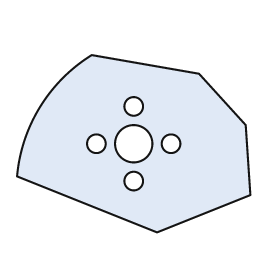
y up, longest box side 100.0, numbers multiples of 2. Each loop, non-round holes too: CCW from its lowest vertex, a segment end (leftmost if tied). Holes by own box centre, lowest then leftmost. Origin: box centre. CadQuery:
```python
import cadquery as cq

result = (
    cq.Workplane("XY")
    .moveTo(10.0, -38.0)
    .lineTo(50.0, -22.0)
    .lineTo(48.0, 8.0)
    .lineTo(28.0, 30.0)
    .lineTo(-18.0, 38.0)
    .threePointArc((-40.0, 16.0), (-50.0, -14.0))
    .close()
    .moveTo(0.0, -16.0)
    .circle(4.0)
    .moveTo(-16.0, 0.0)
    .circle(4.0)
    .moveTo(0.0, 0.0)
    .circle(8.0)
    .moveTo(16.0, 0.0)
    .circle(4.0)
    .moveTo(0.0, 16.0)
    .circle(4.0)
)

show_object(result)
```